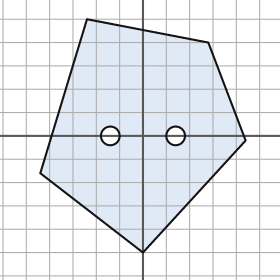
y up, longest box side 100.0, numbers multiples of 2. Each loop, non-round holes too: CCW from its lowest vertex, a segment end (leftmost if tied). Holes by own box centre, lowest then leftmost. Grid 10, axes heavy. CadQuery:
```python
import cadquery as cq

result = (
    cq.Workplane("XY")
    .moveTo(0.0, -50.0)
    .lineTo(44.0, -2.0)
    .lineTo(28.0, 40.0)
    .lineTo(-24.0, 50.0)
    .lineTo(-44.0, -16.0)
    .close()
    .moveTo(-14.0, 0.0)
    .circle(4.0)
    .moveTo(14.0, 0.0)
    .circle(4.0)
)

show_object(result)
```